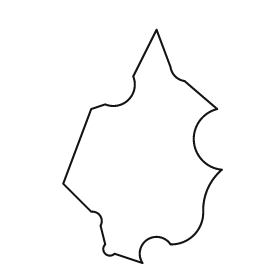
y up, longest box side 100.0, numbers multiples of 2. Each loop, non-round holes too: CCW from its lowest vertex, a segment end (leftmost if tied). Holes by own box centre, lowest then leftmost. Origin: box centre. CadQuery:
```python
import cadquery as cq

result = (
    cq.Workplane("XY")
    .moveTo(0.0, -50.0)
    .threePointArc((2.0, -40.0), (12.0, -42.0))
    .threePointArc((22.0, -38.0), (26.0, -28.0))
    .threePointArc((28.0, -18.0), (34.0, -10.0))
    .threePointArc((22.0, 2.0), (32.0, 16.0))
    .lineTo(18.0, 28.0)
    .threePointArc((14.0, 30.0), (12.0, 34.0))
    .lineTo(6.0, 50.0)
    .lineTo(-4.0, 30.0)
    .threePointArc((-6.0, 20.0), (-16.0, 18.0))
    .lineTo(-22.0, 16.0)
    .lineTo(-34.0, -16.0)
    .lineTo(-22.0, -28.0)
    .threePointArc((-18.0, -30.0), (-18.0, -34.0))
    .lineTo(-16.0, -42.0)
    .threePointArc((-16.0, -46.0), (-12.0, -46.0))
    .close()
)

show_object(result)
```